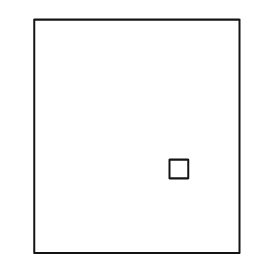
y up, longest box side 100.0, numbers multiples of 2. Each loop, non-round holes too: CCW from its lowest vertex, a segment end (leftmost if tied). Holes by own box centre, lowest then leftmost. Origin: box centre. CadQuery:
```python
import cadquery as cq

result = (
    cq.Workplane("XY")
    .moveTo(-44.0, -50.0)
    .lineTo(44.0, -50.0)
    .lineTo(44.0, 50.0)
    .lineTo(-44.0, 50.0)
    .close()
    .moveTo(14.0, -18.0)
    .lineTo(22.0, -18.0)
    .lineTo(22.0, -10.0)
    .lineTo(14.0, -10.0)
    .close()
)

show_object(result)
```